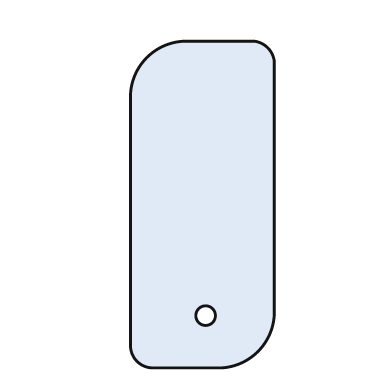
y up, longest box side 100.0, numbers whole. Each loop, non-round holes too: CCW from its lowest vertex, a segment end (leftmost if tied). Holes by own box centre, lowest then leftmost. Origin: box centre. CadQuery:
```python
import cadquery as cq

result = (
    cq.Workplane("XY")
    .moveTo(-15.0, -50.0)
    .lineTo(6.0, -50.0)
    .threePointArc((17.0, -45.0), (22.0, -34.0))
    .lineTo(22.0, 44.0)
    .threePointArc((20.0, 48.0), (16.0, 50.0))
    .lineTo(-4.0, 50.0)
    .threePointArc((-17.0, 45.0), (-22.0, 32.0))
    .lineTo(-22.0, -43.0)
    .threePointArc((-20.0, -48.0), (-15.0, -50.0))
    .close()
    .moveTo(1.0, -34.0)
    .circle(3.0)
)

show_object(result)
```